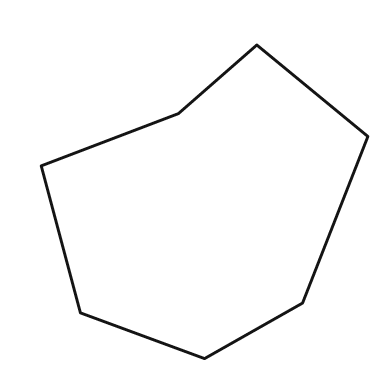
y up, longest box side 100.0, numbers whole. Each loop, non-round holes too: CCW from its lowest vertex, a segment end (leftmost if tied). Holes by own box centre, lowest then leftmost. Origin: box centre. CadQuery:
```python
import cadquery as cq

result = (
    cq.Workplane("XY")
    .moveTo(0.0, -48.0)
    .lineTo(30.0, -31.0)
    .lineTo(50.0, 20.0)
    .lineTo(16.0, 48.0)
    .lineTo(-8.0, 27.0)
    .lineTo(-50.0, 11.0)
    .lineTo(-38.0, -34.0)
    .close()
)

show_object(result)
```